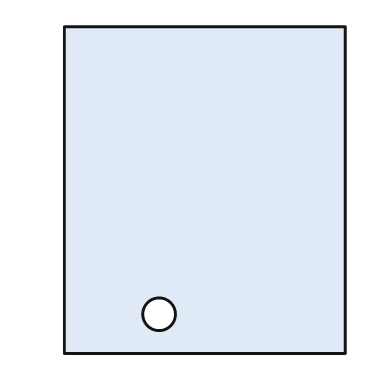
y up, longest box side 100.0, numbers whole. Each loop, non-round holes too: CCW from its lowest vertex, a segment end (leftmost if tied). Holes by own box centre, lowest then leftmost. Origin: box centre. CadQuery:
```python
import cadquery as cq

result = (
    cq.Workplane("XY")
    .moveTo(-43.0, -50.0)
    .lineTo(43.0, -50.0)
    .lineTo(43.0, 50.0)
    .lineTo(-43.0, 50.0)
    .close()
    .moveTo(-14.0, -38.0)
    .circle(5.0)
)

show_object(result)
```